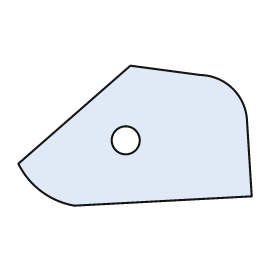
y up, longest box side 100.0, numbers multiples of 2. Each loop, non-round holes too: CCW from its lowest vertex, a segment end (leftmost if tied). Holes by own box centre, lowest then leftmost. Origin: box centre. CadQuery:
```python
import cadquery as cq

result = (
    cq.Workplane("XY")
    .moveTo(-26.0, -30.0)
    .lineTo(50.0, -26.0)
    .lineTo(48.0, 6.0)
    .threePointArc((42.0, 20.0), (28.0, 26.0))
    .lineTo(-2.0, 30.0)
    .lineTo(-50.0, -12.0)
    .threePointArc((-40.0, -24.0), (-26.0, -30.0))
    .close()
    .moveTo(-4.0, -2.0)
    .circle(6.0)
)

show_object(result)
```